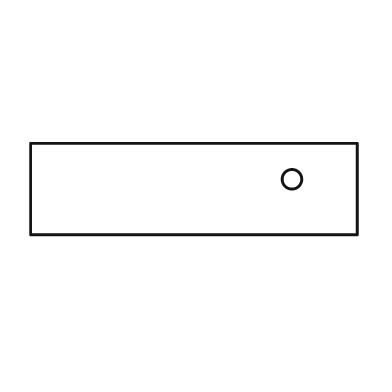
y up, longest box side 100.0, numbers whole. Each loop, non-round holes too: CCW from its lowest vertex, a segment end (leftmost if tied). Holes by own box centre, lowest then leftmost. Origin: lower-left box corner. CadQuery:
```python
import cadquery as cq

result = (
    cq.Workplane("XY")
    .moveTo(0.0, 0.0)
    .lineTo(100.0, 0.0)
    .lineTo(100.0, 28.0)
    .lineTo(0.0, 28.0)
    .close()
    .moveTo(80.0, 17.0)
    .circle(3.0)
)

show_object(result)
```